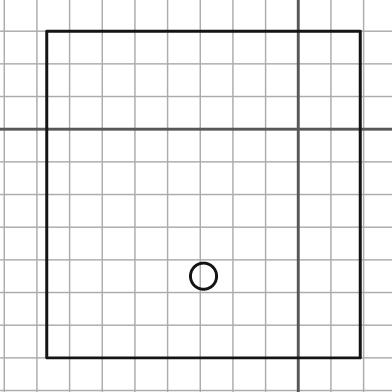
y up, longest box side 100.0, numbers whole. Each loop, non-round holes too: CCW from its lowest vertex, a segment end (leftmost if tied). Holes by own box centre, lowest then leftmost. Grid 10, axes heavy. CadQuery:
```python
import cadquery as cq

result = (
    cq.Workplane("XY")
    .moveTo(-77.0, -70.0)
    .lineTo(19.0, -70.0)
    .lineTo(19.0, 30.0)
    .lineTo(-77.0, 30.0)
    .close()
    .moveTo(-29.0, -45.0)
    .circle(4.0)
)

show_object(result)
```